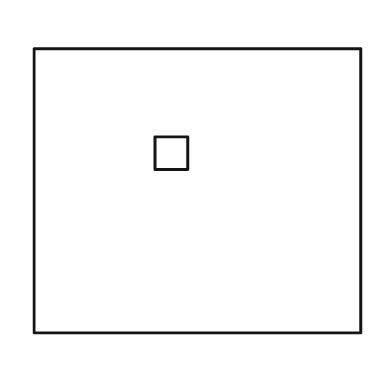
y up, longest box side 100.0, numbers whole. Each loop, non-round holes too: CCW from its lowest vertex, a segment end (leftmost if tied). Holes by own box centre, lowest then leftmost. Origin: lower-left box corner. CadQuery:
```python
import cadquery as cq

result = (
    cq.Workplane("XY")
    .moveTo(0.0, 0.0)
    .lineTo(100.0, 0.0)
    .lineTo(100.0, 87.0)
    .lineTo(0.0, 87.0)
    .close()
    .moveTo(37.0, 50.0)
    .lineTo(47.0, 50.0)
    .lineTo(47.0, 60.0)
    .lineTo(37.0, 60.0)
    .close()
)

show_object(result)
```